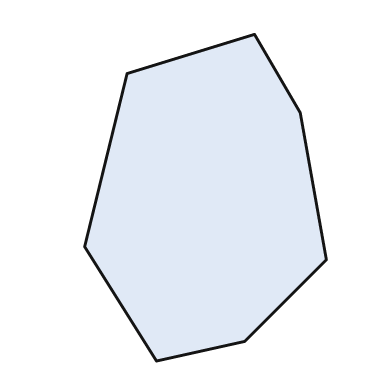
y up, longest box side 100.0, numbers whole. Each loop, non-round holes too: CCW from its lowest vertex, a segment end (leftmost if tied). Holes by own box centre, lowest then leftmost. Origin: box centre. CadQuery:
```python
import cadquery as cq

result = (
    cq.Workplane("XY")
    .moveTo(-15.0, -50.0)
    .lineTo(12.0, -44.0)
    .lineTo(37.0, -19.0)
    .lineTo(29.0, 26.0)
    .lineTo(15.0, 50.0)
    .lineTo(-24.0, 38.0)
    .lineTo(-37.0, -15.0)
    .close()
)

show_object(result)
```